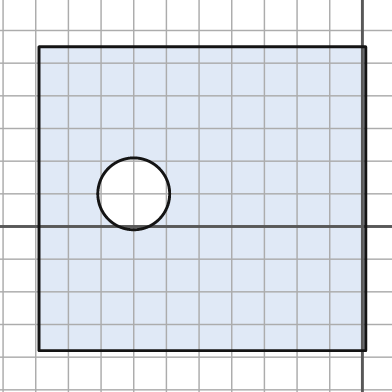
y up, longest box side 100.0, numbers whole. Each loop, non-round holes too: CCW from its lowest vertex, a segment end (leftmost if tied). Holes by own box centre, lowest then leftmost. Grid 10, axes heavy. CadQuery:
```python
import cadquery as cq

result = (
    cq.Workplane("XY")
    .moveTo(-99.0, -38.0)
    .lineTo(1.0, -38.0)
    .lineTo(1.0, 55.0)
    .lineTo(-99.0, 55.0)
    .close()
    .moveTo(-70.0, 10.0)
    .circle(11.0)
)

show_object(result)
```